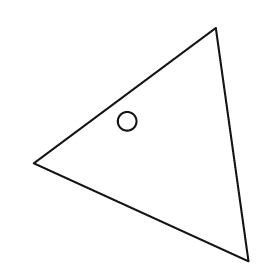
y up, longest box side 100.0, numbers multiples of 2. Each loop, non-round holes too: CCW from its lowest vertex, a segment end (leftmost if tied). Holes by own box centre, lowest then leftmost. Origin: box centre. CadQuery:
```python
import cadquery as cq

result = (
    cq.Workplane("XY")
    .moveTo(46.0, -50.0)
    .lineTo(32.0, 50.0)
    .lineTo(-46.0, -8.0)
    .close()
    .moveTo(-6.0, 10.0)
    .circle(4.0)
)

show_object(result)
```